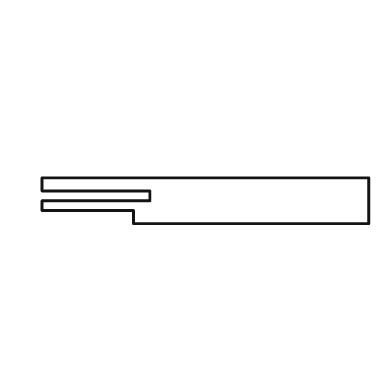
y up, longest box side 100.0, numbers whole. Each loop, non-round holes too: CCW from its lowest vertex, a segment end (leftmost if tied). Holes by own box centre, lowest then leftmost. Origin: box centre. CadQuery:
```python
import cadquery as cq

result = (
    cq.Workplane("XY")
    .moveTo(-22.0, -7.0)
    .lineTo(50.0, -7.0)
    .lineTo(50.0, 7.0)
    .lineTo(-50.0, 7.0)
    .lineTo(-50.0, 3.0)
    .lineTo(-17.0, 3.0)
    .lineTo(-17.0, 0.0)
    .lineTo(-50.0, 0.0)
    .lineTo(-50.0, -3.0)
    .lineTo(-22.0, -3.0)
    .close()
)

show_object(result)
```